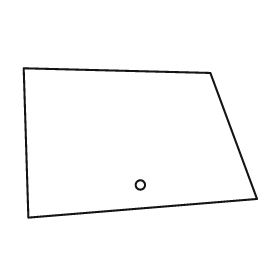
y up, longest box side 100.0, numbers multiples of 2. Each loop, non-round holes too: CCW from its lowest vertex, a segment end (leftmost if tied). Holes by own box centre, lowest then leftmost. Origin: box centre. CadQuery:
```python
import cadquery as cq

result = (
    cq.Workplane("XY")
    .moveTo(-48.0, -32.0)
    .lineTo(50.0, -24.0)
    .lineTo(30.0, 30.0)
    .lineTo(-50.0, 32.0)
    .close()
    .moveTo(0.0, -18.0)
    .circle(2.0)
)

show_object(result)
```